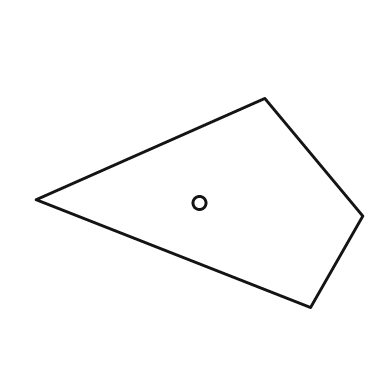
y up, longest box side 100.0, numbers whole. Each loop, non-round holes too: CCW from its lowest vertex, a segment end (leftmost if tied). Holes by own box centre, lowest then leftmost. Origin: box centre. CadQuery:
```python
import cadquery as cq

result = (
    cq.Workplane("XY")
    .moveTo(34.0, -32.0)
    .lineTo(50.0, -4.0)
    .lineTo(20.0, 32.0)
    .lineTo(-50.0, 1.0)
    .close()
    .moveTo(0.0, 0.0)
    .circle(2.0)
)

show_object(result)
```